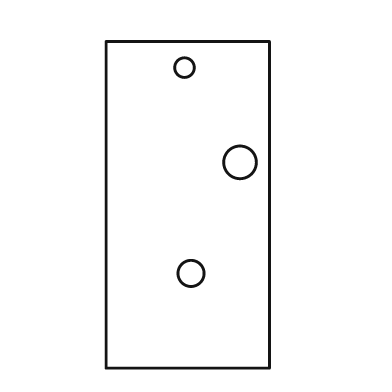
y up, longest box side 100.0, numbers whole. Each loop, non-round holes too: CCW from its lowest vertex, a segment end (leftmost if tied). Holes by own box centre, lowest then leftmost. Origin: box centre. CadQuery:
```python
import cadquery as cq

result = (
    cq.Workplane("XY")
    .moveTo(-25.0, -50.0)
    .lineTo(25.0, -50.0)
    .lineTo(25.0, 50.0)
    .lineTo(-25.0, 50.0)
    .close()
    .moveTo(1.0, -21.0)
    .circle(4.0)
    .moveTo(16.0, 13.0)
    .circle(5.0)
    .moveTo(-1.0, 42.0)
    .circle(3.0)
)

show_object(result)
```